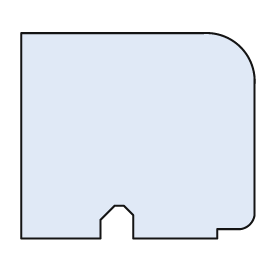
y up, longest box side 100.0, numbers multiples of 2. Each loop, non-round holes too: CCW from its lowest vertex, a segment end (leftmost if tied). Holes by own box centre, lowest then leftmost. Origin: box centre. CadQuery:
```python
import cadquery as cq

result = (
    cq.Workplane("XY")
    .moveTo(-50.0, -44.0)
    .lineTo(-16.0, -44.0)
    .lineTo(-16.0, -36.0)
    .lineTo(-10.0, -30.0)
    .lineTo(-6.0, -30.0)
    .lineTo(-2.0, -34.0)
    .lineTo(-2.0, -44.0)
    .lineTo(34.0, -44.0)
    .lineTo(34.0, -40.0)
    .lineTo(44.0, -40.0)
    .threePointArc((48.0, -38.0), (50.0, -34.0))
    .lineTo(50.0, 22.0)
    .threePointArc((44.0, 38.0), (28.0, 44.0))
    .lineTo(-50.0, 44.0)
    .close()
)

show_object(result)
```